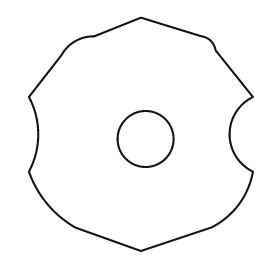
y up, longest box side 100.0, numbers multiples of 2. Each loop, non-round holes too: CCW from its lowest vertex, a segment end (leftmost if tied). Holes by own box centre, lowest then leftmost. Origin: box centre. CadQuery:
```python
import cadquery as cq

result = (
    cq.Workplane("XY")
    .moveTo(0.0, -50.0)
    .lineTo(30.0, -40.0)
    .threePointArc((42.0, -30.0), (48.0, -16.0))
    .threePointArc((38.0, 0.0), (48.0, 16.0))
    .lineTo(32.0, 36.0)
    .threePointArc((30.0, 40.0), (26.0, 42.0))
    .lineTo(0.0, 50.0)
    .lineTo(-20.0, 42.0)
    .threePointArc((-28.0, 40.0), (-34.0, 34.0))
    .lineTo(-48.0, 16.0)
    .threePointArc((-44.0, 0.0), (-48.0, -16.0))
    .threePointArc((-40.0, -30.0), (-28.0, -40.0))
    .close()
    .moveTo(2.0, -2.0)
    .circle(12.0)
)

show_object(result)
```